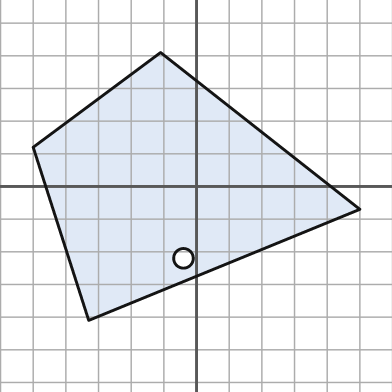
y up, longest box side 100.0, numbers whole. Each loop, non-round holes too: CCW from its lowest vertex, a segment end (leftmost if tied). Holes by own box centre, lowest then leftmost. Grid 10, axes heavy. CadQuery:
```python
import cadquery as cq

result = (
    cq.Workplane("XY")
    .moveTo(-33.0, -41.0)
    .lineTo(50.0, -7.0)
    .lineTo(-11.0, 41.0)
    .lineTo(-50.0, 12.0)
    .close()
    .moveTo(-4.0, -22.0)
    .circle(3.0)
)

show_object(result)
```